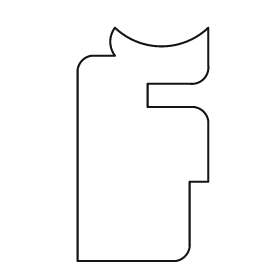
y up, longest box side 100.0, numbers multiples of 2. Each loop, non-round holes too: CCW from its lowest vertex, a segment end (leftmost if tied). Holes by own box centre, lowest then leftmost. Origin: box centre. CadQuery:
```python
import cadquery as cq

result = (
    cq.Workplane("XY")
    .moveTo(-28.0, -50.0)
    .lineTo(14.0, -50.0)
    .threePointArc((18.0, -48.0), (20.0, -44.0))
    .lineTo(20.0, -16.0)
    .lineTo(28.0, -16.0)
    .lineTo(28.0, 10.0)
    .threePointArc((26.0, 14.0), (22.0, 16.0))
    .lineTo(2.0, 16.0)
    .lineTo(2.0, 26.0)
    .lineTo(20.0, 26.0)
    .threePointArc((26.0, 28.0), (28.0, 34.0))
    .lineTo(28.0, 50.0)
    .threePointArc((8.0, 42.0), (-12.0, 50.0))
    .threePointArc((-14.0, 44.0), (-12.0, 38.0))
    .lineTo(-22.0, 38.0)
    .threePointArc((-26.0, 36.0), (-28.0, 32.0))
    .close()
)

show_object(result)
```